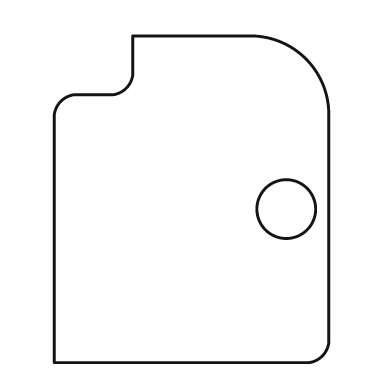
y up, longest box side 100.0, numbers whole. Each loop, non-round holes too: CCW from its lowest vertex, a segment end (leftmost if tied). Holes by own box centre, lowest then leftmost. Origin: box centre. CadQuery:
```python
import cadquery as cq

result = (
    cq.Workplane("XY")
    .moveTo(-42.0, -50.0)
    .lineTo(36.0, -50.0)
    .threePointArc((40.0, -48.0), (42.0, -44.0))
    .lineTo(42.0, 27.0)
    .threePointArc((35.0, 43.0), (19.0, 50.0))
    .lineTo(-18.0, 50.0)
    .lineTo(-18.0, 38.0)
    .threePointArc((-20.0, 34.0), (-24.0, 32.0))
    .lineTo(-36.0, 32.0)
    .threePointArc((-40.0, 30.0), (-42.0, 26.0))
    .close()
    .moveTo(29.0, -3.0)
    .circle(9.0)
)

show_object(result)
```